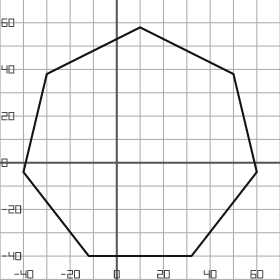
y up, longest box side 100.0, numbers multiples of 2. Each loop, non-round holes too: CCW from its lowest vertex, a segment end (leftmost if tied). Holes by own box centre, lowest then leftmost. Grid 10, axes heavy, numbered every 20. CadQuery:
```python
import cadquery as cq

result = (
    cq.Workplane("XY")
    .moveTo(-12.0, -40.0)
    .lineTo(32.0, -40.0)
    .lineTo(60.0, -4.0)
    .lineTo(50.0, 38.0)
    .lineTo(10.0, 58.0)
    .lineTo(-30.0, 38.0)
    .lineTo(-40.0, -4.0)
    .close()
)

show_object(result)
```